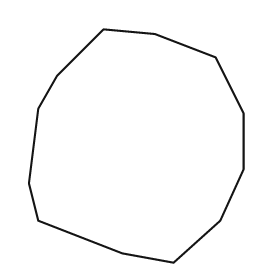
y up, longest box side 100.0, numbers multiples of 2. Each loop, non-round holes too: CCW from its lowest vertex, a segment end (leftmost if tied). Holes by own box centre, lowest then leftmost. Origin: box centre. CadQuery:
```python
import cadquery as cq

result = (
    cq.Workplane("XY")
    .moveTo(16.0, -50.0)
    .lineTo(36.0, -32.0)
    .lineTo(46.0, -10.0)
    .lineTo(46.0, 14.0)
    .lineTo(34.0, 38.0)
    .lineTo(8.0, 48.0)
    .lineTo(-14.0, 50.0)
    .lineTo(-34.0, 30.0)
    .lineTo(-42.0, 16.0)
    .lineTo(-46.0, -16.0)
    .lineTo(-42.0, -32.0)
    .lineTo(-6.0, -46.0)
    .close()
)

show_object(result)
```